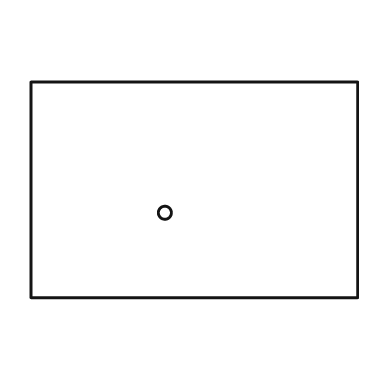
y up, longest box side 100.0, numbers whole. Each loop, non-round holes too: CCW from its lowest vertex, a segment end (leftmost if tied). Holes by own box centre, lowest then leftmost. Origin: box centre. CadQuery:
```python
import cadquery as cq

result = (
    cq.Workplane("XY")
    .moveTo(-50.0, -33.0)
    .lineTo(50.0, -33.0)
    .lineTo(50.0, 33.0)
    .lineTo(-50.0, 33.0)
    .close()
    .moveTo(-9.0, -7.0)
    .circle(2.0)
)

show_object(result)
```